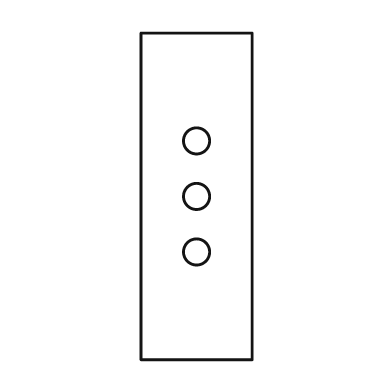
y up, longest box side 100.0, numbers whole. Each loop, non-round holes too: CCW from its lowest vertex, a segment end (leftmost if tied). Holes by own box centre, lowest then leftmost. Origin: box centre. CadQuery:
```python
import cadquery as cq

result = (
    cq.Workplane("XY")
    .moveTo(-17.0, -50.0)
    .lineTo(17.0, -50.0)
    .lineTo(17.0, 50.0)
    .lineTo(-17.0, 50.0)
    .close()
    .moveTo(0.0, -17.0)
    .circle(4.0)
    .moveTo(0.0, 0.0)
    .circle(4.0)
    .moveTo(0.0, 17.0)
    .circle(4.0)
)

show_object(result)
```